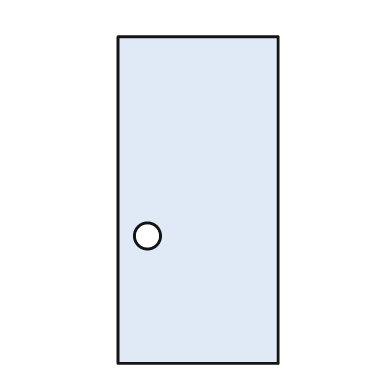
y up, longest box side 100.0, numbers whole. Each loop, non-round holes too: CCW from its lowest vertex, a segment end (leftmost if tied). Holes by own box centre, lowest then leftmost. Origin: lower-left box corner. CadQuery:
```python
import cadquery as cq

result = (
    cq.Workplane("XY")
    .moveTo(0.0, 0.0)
    .lineTo(49.0, 0.0)
    .lineTo(49.0, 100.0)
    .lineTo(0.0, 100.0)
    .close()
    .moveTo(9.0, 39.0)
    .circle(4.0)
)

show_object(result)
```